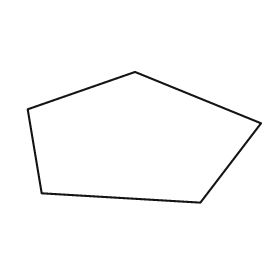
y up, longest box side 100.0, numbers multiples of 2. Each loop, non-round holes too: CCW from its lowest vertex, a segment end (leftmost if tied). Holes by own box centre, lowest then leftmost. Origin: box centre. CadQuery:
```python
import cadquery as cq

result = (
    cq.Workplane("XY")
    .moveTo(24.0, -28.0)
    .lineTo(50.0, 6.0)
    .lineTo(-4.0, 28.0)
    .lineTo(-50.0, 12.0)
    .lineTo(-44.0, -24.0)
    .close()
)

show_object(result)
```